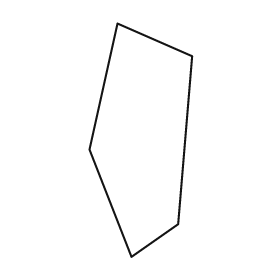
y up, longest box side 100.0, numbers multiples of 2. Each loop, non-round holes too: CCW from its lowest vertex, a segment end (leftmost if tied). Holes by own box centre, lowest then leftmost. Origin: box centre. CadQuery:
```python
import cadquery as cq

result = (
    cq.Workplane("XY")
    .moveTo(-4.0, -50.0)
    .lineTo(16.0, -36.0)
    .lineTo(22.0, 36.0)
    .lineTo(-10.0, 50.0)
    .lineTo(-22.0, -4.0)
    .close()
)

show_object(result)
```